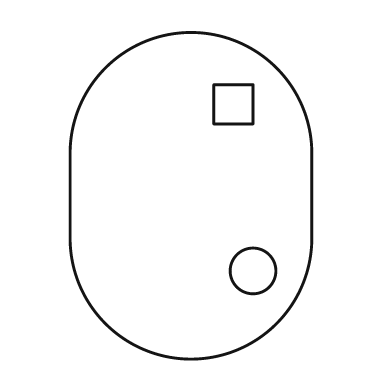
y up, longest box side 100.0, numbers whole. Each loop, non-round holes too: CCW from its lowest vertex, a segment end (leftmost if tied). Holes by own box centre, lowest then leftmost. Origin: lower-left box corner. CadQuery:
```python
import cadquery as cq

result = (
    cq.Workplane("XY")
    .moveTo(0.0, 37.0)
    .threePointArc((37.0, 0.0), (74.0, 37.0))
    .lineTo(74.0, 63.0)
    .threePointArc((37.0, 100.0), (0.0, 63.0))
    .close()
    .moveTo(56.0, 27.0)
    .circle(7.0)
    .moveTo(44.0, 72.0)
    .lineTo(56.0, 72.0)
    .lineTo(56.0, 84.0)
    .lineTo(44.0, 84.0)
    .close()
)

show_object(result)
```